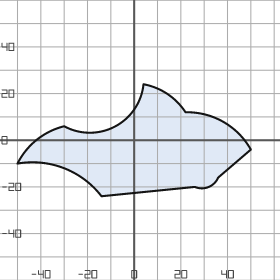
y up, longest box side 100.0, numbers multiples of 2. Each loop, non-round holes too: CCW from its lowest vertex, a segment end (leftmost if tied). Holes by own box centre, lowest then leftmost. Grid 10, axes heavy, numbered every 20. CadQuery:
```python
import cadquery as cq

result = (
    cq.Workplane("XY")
    .moveTo(-14.0, -24.0)
    .lineTo(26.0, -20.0)
    .threePointArc((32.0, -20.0), (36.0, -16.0))
    .lineTo(50.0, -4.0)
    .threePointArc((38.0, 8.0), (22.0, 12.0))
    .threePointArc((14.0, 20.0), (4.0, 24.0))
    .threePointArc((-8.0, 6.0), (-30.0, 6.0))
    .threePointArc((-42.0, 0.0), (-50.0, -10.0))
    .threePointArc((-30.0, -12.0), (-14.0, -24.0))
    .close()
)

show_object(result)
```